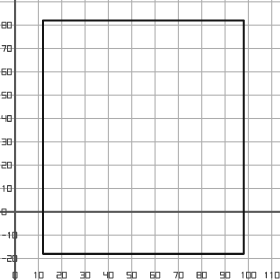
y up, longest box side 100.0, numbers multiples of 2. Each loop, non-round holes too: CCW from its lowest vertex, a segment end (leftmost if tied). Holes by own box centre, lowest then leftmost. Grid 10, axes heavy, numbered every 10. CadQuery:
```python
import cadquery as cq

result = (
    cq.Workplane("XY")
    .moveTo(12.0, -18.0)
    .lineTo(98.0, -18.0)
    .lineTo(98.0, 82.0)
    .lineTo(12.0, 82.0)
    .close()
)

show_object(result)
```